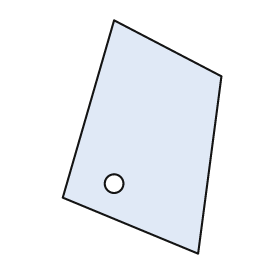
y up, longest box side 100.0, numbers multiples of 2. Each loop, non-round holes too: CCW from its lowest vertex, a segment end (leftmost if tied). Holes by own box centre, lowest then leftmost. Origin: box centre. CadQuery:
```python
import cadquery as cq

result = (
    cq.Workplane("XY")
    .moveTo(24.0, -50.0)
    .lineTo(34.0, 26.0)
    .lineTo(-12.0, 50.0)
    .lineTo(-34.0, -26.0)
    .close()
    .moveTo(-12.0, -20.0)
    .circle(4.0)
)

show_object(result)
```